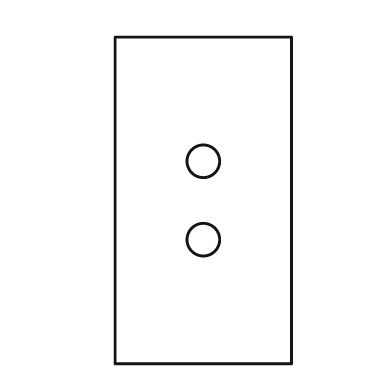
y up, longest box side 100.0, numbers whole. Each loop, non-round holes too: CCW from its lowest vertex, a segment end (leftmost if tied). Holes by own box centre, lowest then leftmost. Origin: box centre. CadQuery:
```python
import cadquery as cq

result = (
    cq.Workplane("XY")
    .moveTo(-27.0, -50.0)
    .lineTo(27.0, -50.0)
    .lineTo(27.0, 50.0)
    .lineTo(-27.0, 50.0)
    .close()
    .moveTo(0.0, -12.0)
    .circle(5.0)
    .moveTo(0.0, 12.0)
    .circle(5.0)
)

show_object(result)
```